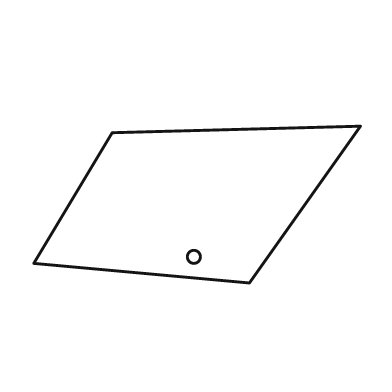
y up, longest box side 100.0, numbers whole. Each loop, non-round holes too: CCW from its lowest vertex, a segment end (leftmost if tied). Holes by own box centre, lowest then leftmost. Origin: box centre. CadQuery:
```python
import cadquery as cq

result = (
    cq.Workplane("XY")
    .moveTo(16.0, -24.0)
    .lineTo(50.0, 24.0)
    .lineTo(-26.0, 22.0)
    .lineTo(-50.0, -18.0)
    .close()
    .moveTo(-1.0, -16.0)
    .circle(2.0)
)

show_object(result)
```